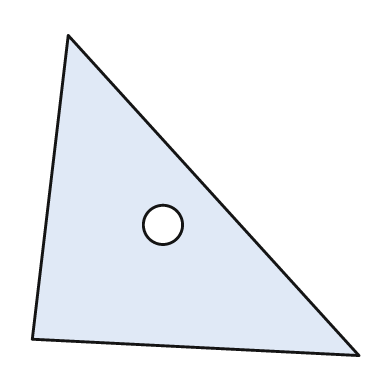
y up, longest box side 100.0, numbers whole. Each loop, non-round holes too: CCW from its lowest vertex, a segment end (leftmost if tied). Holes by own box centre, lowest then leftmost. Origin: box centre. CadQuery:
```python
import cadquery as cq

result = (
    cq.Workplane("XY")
    .moveTo(50.0, -49.0)
    .lineTo(-39.0, 49.0)
    .lineTo(-50.0, -44.0)
    .close()
    .moveTo(-10.0, -9.0)
    .circle(6.0)
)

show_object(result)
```